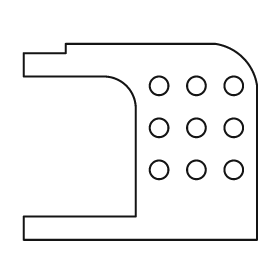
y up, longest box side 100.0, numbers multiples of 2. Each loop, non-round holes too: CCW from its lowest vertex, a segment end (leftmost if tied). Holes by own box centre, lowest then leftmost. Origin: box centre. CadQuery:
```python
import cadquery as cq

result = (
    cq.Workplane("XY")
    .moveTo(-50.0, -42.0)
    .lineTo(50.0, -42.0)
    .lineTo(50.0, 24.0)
    .threePointArc((44.0, 36.0), (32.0, 42.0))
    .lineTo(-32.0, 42.0)
    .lineTo(-32.0, 38.0)
    .lineTo(-50.0, 38.0)
    .lineTo(-50.0, 28.0)
    .lineTo(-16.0, 28.0)
    .threePointArc((-6.0, 24.0), (-2.0, 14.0))
    .lineTo(-2.0, -32.0)
    .lineTo(-50.0, -32.0)
    .close()
    .moveTo(8.0, -12.0)
    .circle(4.0)
    .moveTo(24.0, -12.0)
    .circle(4.0)
    .moveTo(40.0, -12.0)
    .circle(4.0)
    .moveTo(8.0, 6.0)
    .circle(4.0)
    .moveTo(24.0, 6.0)
    .circle(4.0)
    .moveTo(40.0, 6.0)
    .circle(4.0)
    .moveTo(8.0, 24.0)
    .circle(4.0)
    .moveTo(24.0, 24.0)
    .circle(4.0)
    .moveTo(40.0, 24.0)
    .circle(4.0)
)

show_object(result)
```